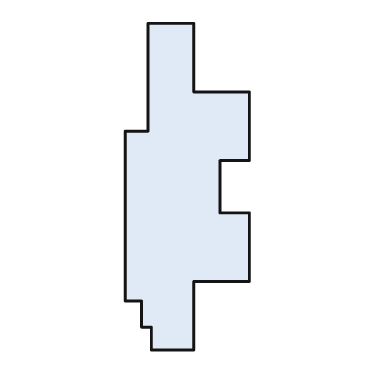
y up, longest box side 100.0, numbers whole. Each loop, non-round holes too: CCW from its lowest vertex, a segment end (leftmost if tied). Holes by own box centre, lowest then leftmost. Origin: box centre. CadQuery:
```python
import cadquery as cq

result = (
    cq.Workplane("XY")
    .moveTo(-11.0, -50.0)
    .lineTo(2.0, -50.0)
    .lineTo(2.0, -29.0)
    .lineTo(19.0, -29.0)
    .lineTo(19.0, -8.0)
    .lineTo(10.0, -8.0)
    .lineTo(10.0, 8.0)
    .lineTo(19.0, 8.0)
    .lineTo(19.0, 29.0)
    .lineTo(2.0, 29.0)
    .lineTo(2.0, 50.0)
    .lineTo(-12.0, 50.0)
    .lineTo(-12.0, 17.0)
    .lineTo(-19.0, 17.0)
    .lineTo(-19.0, -35.0)
    .lineTo(-14.0, -35.0)
    .lineTo(-14.0, -43.0)
    .lineTo(-11.0, -43.0)
    .close()
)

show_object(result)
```